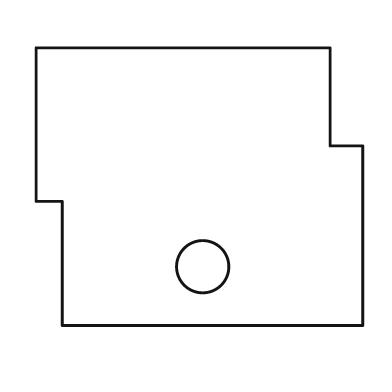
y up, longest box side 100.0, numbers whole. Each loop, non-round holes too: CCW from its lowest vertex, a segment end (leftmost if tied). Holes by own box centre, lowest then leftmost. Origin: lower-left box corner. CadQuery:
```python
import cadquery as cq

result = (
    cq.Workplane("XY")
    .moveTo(8.0, 0.0)
    .lineTo(100.0, 0.0)
    .lineTo(100.0, 55.0)
    .lineTo(90.0, 55.0)
    .lineTo(90.0, 85.0)
    .lineTo(0.0, 85.0)
    .lineTo(0.0, 38.0)
    .lineTo(8.0, 38.0)
    .close()
    .moveTo(51.0, 18.0)
    .circle(8.0)
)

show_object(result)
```